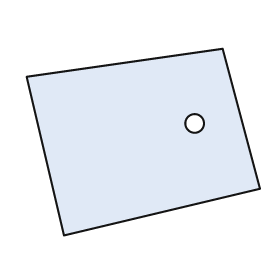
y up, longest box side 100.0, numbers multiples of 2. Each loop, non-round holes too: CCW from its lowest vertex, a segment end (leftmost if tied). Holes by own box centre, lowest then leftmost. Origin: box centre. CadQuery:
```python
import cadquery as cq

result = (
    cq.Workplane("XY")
    .moveTo(-34.0, -40.0)
    .lineTo(50.0, -20.0)
    .lineTo(34.0, 40.0)
    .lineTo(-50.0, 28.0)
    .close()
    .moveTo(22.0, 8.0)
    .circle(4.0)
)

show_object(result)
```